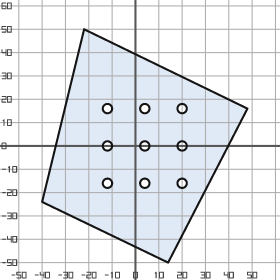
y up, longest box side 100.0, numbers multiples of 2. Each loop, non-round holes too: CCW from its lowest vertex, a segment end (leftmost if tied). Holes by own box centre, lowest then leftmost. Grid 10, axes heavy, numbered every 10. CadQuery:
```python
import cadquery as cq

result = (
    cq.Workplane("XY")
    .moveTo(14.0, -50.0)
    .lineTo(48.0, 16.0)
    .lineTo(-22.0, 50.0)
    .lineTo(-40.0, -24.0)
    .close()
    .moveTo(-12.0, -16.0)
    .circle(2.0)
    .moveTo(4.0, -16.0)
    .circle(2.0)
    .moveTo(20.0, -16.0)
    .circle(2.0)
    .moveTo(-12.0, 0.0)
    .circle(2.0)
    .moveTo(4.0, 0.0)
    .circle(2.0)
    .moveTo(20.0, 0.0)
    .circle(2.0)
    .moveTo(-12.0, 16.0)
    .circle(2.0)
    .moveTo(4.0, 16.0)
    .circle(2.0)
    .moveTo(20.0, 16.0)
    .circle(2.0)
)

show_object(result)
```